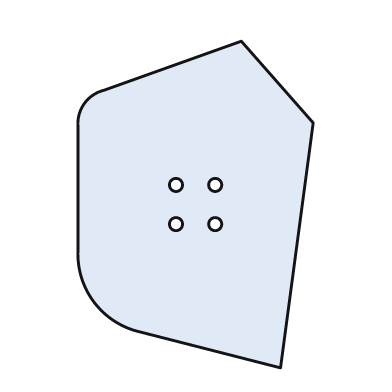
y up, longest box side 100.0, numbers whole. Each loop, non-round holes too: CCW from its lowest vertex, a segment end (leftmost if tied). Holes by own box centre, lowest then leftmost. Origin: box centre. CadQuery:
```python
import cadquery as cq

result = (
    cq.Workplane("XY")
    .moveTo(26.0, -50.0)
    .lineTo(36.0, 25.0)
    .lineTo(14.0, 50.0)
    .lineTo(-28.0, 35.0)
    .threePointArc((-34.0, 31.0), (-36.0, 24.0))
    .lineTo(-36.0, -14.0)
    .threePointArc((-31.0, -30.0), (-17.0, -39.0))
    .close()
    .moveTo(-6.0, -6.0)
    .circle(2.0)
    .moveTo(6.0, -6.0)
    .circle(2.0)
    .moveTo(-6.0, 6.0)
    .circle(2.0)
    .moveTo(6.0, 6.0)
    .circle(2.0)
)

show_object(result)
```